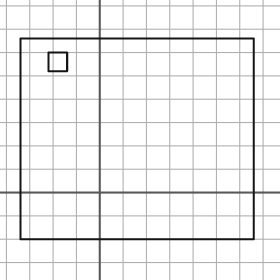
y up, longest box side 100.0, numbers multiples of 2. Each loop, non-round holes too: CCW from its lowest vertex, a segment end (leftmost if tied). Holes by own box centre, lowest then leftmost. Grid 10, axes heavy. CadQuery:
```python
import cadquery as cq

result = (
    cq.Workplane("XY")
    .moveTo(-34.0, -20.0)
    .lineTo(66.0, -20.0)
    .lineTo(66.0, 66.0)
    .lineTo(-34.0, 66.0)
    .close()
    .moveTo(-22.0, 52.0)
    .lineTo(-14.0, 52.0)
    .lineTo(-14.0, 60.0)
    .lineTo(-22.0, 60.0)
    .close()
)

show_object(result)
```